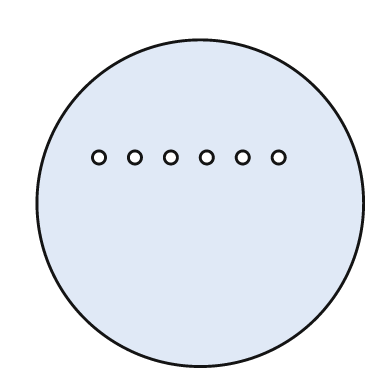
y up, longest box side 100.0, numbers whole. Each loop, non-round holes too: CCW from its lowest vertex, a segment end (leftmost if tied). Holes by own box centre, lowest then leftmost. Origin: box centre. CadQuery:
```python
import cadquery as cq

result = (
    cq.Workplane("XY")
    .moveTo(0.0, 0.0)
    .circle(50.0)
    .moveTo(-31.0, 14.0)
    .circle(2.0)
    .moveTo(-20.0, 14.0)
    .circle(2.0)
    .moveTo(-9.0, 14.0)
    .circle(2.0)
    .moveTo(2.0, 14.0)
    .circle(2.0)
    .moveTo(13.0, 14.0)
    .circle(2.0)
    .moveTo(24.0, 14.0)
    .circle(2.0)
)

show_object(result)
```